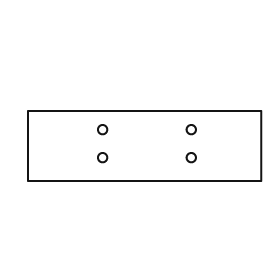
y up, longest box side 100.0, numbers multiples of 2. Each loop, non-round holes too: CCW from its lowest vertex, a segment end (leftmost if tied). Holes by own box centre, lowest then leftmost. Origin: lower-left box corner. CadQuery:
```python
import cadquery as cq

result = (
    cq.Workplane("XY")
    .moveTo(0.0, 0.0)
    .lineTo(100.0, 0.0)
    .lineTo(100.0, 30.0)
    .lineTo(0.0, 30.0)
    .close()
    .moveTo(32.0, 10.0)
    .circle(2.0)
    .moveTo(70.0, 10.0)
    .circle(2.0)
    .moveTo(32.0, 22.0)
    .circle(2.0)
    .moveTo(70.0, 22.0)
    .circle(2.0)
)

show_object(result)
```